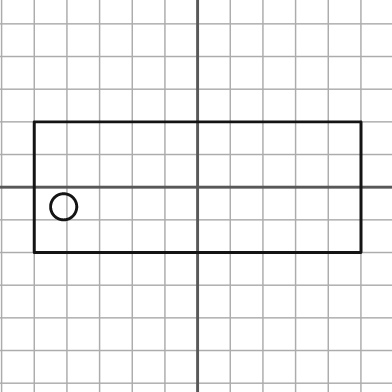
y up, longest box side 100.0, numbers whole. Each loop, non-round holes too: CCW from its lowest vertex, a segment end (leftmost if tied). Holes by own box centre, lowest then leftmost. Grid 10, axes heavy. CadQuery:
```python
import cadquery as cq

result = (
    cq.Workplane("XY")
    .moveTo(-50.0, -20.0)
    .lineTo(50.0, -20.0)
    .lineTo(50.0, 20.0)
    .lineTo(-50.0, 20.0)
    .close()
    .moveTo(-41.0, -6.0)
    .circle(4.0)
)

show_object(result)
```